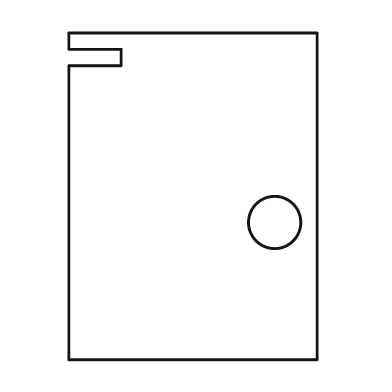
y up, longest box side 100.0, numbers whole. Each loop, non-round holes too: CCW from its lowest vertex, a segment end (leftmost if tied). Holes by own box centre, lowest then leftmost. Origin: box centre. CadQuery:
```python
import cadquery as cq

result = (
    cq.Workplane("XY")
    .moveTo(-38.0, -50.0)
    .lineTo(38.0, -50.0)
    .lineTo(38.0, 50.0)
    .lineTo(-38.0, 50.0)
    .lineTo(-38.0, 45.0)
    .lineTo(-22.0, 45.0)
    .lineTo(-22.0, 40.0)
    .lineTo(-38.0, 40.0)
    .close()
    .moveTo(25.0, -8.0)
    .circle(8.0)
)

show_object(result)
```